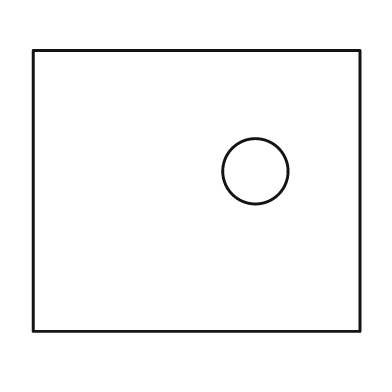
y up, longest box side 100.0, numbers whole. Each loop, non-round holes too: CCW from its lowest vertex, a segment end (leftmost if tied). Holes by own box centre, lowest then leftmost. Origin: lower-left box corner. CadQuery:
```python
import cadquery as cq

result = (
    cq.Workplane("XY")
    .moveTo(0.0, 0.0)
    .lineTo(100.0, 0.0)
    .lineTo(100.0, 86.0)
    .lineTo(0.0, 86.0)
    .close()
    .moveTo(68.0, 49.0)
    .circle(10.0)
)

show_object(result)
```